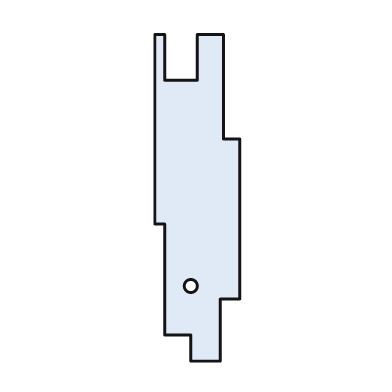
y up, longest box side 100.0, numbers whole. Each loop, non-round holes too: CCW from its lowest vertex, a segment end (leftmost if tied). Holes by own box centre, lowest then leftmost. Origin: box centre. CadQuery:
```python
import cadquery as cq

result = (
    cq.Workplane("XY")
    .moveTo(-2.0, -50.0)
    .lineTo(7.0, -50.0)
    .lineTo(7.0, -31.0)
    .lineTo(13.0, -31.0)
    .lineTo(13.0, 18.0)
    .lineTo(8.0, 18.0)
    .lineTo(8.0, 50.0)
    .lineTo(0.0, 50.0)
    .lineTo(0.0, 36.0)
    .lineTo(-10.0, 36.0)
    .lineTo(-10.0, 50.0)
    .lineTo(-13.0, 50.0)
    .lineTo(-13.0, -8.0)
    .lineTo(-10.0, -8.0)
    .lineTo(-10.0, -42.0)
    .lineTo(-2.0, -42.0)
    .close()
    .moveTo(-2.0, -27.0)
    .circle(2.0)
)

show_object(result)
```